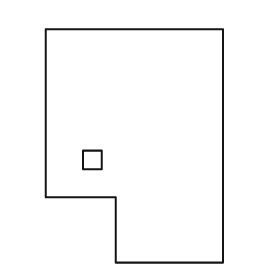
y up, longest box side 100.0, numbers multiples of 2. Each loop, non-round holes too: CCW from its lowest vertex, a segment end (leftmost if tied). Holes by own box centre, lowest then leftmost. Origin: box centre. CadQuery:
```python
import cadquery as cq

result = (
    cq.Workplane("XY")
    .moveTo(-8.0, -50.0)
    .lineTo(38.0, -50.0)
    .lineTo(38.0, 50.0)
    .lineTo(-38.0, 50.0)
    .lineTo(-38.0, -22.0)
    .lineTo(-8.0, -22.0)
    .close()
    .moveTo(-22.0, -10.0)
    .lineTo(-14.0, -10.0)
    .lineTo(-14.0, -2.0)
    .lineTo(-22.0, -2.0)
    .close()
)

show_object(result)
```